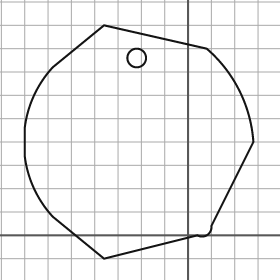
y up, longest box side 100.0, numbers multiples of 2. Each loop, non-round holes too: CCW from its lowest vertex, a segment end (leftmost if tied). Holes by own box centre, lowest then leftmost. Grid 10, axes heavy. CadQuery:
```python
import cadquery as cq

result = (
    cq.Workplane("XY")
    .moveTo(-36.0, -10.0)
    .lineTo(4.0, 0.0)
    .threePointArc((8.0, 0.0), (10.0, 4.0))
    .lineTo(28.0, 40.0)
    .threePointArc((22.0, 62.0), (8.0, 80.0))
    .lineTo(-36.0, 90.0)
    .lineTo(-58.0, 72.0)
    .threePointArc((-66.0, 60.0), (-70.0, 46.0))
    .lineTo(-70.0, 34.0)
    .threePointArc((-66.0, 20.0), (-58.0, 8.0))
    .close()
    .moveTo(-22.0, 76.0)
    .circle(4.0)
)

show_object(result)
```